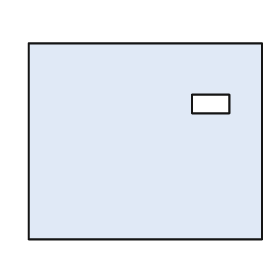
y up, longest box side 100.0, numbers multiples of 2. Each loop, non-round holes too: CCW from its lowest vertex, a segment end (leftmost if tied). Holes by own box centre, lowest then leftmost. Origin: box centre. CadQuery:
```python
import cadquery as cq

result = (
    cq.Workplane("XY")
    .moveTo(-50.0, -42.0)
    .lineTo(50.0, -42.0)
    .lineTo(50.0, 42.0)
    .lineTo(-50.0, 42.0)
    .close()
    .moveTo(20.0, 12.0)
    .lineTo(36.0, 12.0)
    .lineTo(36.0, 20.0)
    .lineTo(20.0, 20.0)
    .close()
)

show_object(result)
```